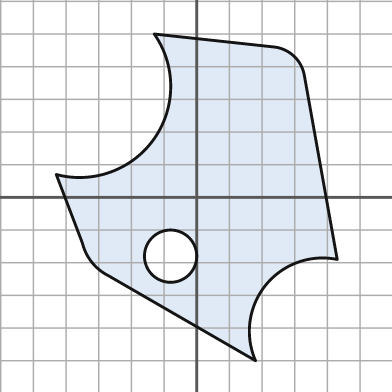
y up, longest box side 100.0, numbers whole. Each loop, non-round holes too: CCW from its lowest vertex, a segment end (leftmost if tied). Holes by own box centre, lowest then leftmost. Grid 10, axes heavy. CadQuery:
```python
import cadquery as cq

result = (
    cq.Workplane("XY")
    .moveTo(18.0, -50.0)
    .threePointArc((21.0, -27.0), (43.0, -19.0))
    .lineTo(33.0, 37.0)
    .threePointArc((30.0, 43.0), (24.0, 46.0))
    .lineTo(-13.0, 50.0)
    .threePointArc((-13.0, 18.0), (-43.0, 7.0))
    .lineTo(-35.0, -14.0)
    .threePointArc((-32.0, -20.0), (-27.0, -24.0))
    .close()
    .moveTo(-8.0, -18.0)
    .circle(8.0)
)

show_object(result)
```